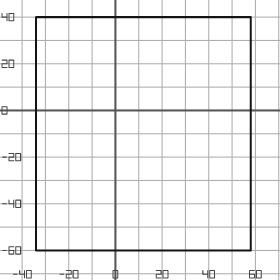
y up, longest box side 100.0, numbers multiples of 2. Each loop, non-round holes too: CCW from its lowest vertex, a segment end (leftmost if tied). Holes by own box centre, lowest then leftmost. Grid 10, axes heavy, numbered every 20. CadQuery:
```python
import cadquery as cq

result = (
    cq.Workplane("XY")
    .moveTo(-34.0, -60.0)
    .lineTo(58.0, -60.0)
    .lineTo(58.0, 40.0)
    .lineTo(-34.0, 40.0)
    .close()
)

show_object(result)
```